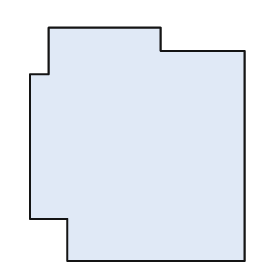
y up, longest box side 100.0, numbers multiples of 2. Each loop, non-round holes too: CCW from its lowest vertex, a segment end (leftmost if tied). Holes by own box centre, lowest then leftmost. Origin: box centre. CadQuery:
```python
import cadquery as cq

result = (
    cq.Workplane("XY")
    .moveTo(-30.0, -50.0)
    .lineTo(46.0, -50.0)
    .lineTo(46.0, 40.0)
    .lineTo(10.0, 40.0)
    .lineTo(10.0, 50.0)
    .lineTo(-38.0, 50.0)
    .lineTo(-38.0, 30.0)
    .lineTo(-46.0, 30.0)
    .lineTo(-46.0, -32.0)
    .lineTo(-30.0, -32.0)
    .close()
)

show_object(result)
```